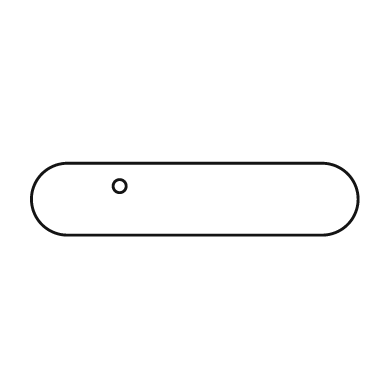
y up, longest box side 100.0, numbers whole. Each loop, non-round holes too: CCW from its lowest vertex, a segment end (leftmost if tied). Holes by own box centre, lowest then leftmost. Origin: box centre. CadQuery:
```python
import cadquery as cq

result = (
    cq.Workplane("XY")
    .moveTo(-39.0, -11.0)
    .lineTo(39.0, -11.0)
    .threePointArc((50.0, 0.0), (39.0, 11.0))
    .lineTo(-39.0, 11.0)
    .threePointArc((-50.0, 0.0), (-39.0, -11.0))
    .close()
    .moveTo(-23.0, 4.0)
    .circle(2.0)
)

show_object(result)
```